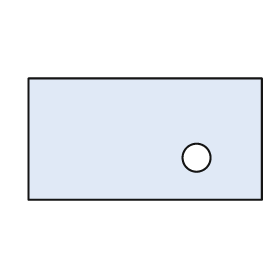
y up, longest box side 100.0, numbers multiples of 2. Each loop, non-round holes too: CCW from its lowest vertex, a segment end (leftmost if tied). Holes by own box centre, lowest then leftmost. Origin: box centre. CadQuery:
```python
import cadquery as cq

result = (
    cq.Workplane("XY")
    .moveTo(-50.0, -26.0)
    .lineTo(50.0, -26.0)
    .lineTo(50.0, 26.0)
    .lineTo(-50.0, 26.0)
    .close()
    .moveTo(22.0, -8.0)
    .circle(6.0)
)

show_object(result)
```